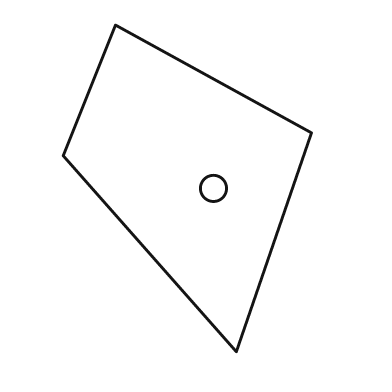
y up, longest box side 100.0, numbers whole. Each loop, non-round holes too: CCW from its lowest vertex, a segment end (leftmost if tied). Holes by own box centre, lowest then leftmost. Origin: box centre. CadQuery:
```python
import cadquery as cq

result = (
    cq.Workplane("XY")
    .moveTo(15.0, -50.0)
    .lineTo(38.0, 17.0)
    .lineTo(-22.0, 50.0)
    .lineTo(-38.0, 10.0)
    .close()
    .moveTo(8.0, 0.0)
    .circle(4.0)
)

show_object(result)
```